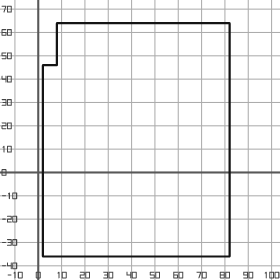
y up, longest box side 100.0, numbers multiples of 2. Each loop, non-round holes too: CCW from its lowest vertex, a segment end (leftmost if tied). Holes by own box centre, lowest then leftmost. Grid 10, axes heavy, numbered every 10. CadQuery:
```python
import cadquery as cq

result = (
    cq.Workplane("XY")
    .moveTo(2.0, -36.0)
    .lineTo(82.0, -36.0)
    .lineTo(82.0, 64.0)
    .lineTo(8.0, 64.0)
    .lineTo(8.0, 46.0)
    .lineTo(2.0, 46.0)
    .close()
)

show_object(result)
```